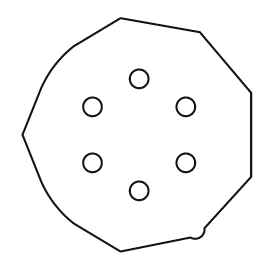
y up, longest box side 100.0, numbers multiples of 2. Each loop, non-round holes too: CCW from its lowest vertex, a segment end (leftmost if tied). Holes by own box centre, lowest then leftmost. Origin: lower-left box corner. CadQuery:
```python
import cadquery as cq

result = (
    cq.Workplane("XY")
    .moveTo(42.0, 0.0)
    .lineTo(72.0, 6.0)
    .threePointArc((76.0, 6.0), (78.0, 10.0))
    .lineTo(98.0, 32.0)
    .lineTo(98.0, 68.0)
    .lineTo(76.0, 94.0)
    .lineTo(42.0, 100.0)
    .lineTo(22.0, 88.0)
    .threePointArc((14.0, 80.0), (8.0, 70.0))
    .lineTo(0.0, 50.0)
    .lineTo(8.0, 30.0)
    .threePointArc((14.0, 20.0), (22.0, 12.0))
    .close()
    .moveTo(50.0, 26.0)
    .circle(4.0)
    .moveTo(30.0, 38.0)
    .circle(4.0)
    .moveTo(70.0, 38.0)
    .circle(4.0)
    .moveTo(30.0, 62.0)
    .circle(4.0)
    .moveTo(70.0, 62.0)
    .circle(4.0)
    .moveTo(50.0, 74.0)
    .circle(4.0)
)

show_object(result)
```